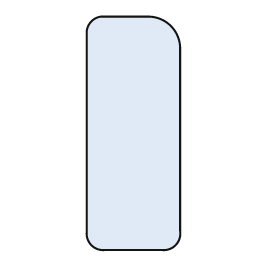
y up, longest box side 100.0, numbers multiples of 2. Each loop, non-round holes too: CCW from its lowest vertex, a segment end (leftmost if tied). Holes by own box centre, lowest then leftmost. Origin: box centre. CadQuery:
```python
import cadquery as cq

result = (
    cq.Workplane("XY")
    .moveTo(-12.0, -50.0)
    .lineTo(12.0, -50.0)
    .threePointArc((18.0, -48.0), (20.0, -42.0))
    .lineTo(20.0, 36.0)
    .threePointArc((16.0, 46.0), (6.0, 50.0))
    .lineTo(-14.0, 50.0)
    .threePointArc((-18.0, 48.0), (-20.0, 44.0))
    .lineTo(-20.0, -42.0)
    .threePointArc((-18.0, -48.0), (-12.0, -50.0))
    .close()
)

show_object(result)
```